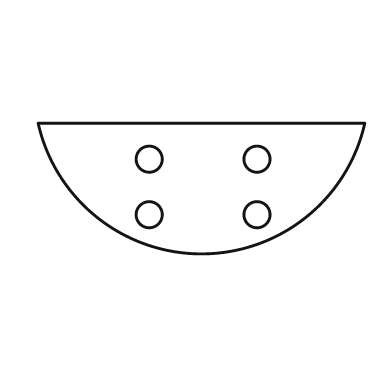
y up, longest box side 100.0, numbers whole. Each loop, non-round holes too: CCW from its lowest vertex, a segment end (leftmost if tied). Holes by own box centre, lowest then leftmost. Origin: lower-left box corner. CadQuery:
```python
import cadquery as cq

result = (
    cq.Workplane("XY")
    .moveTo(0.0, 40.0)
    .threePointArc((50.0, 0.0), (100.0, 40.0))
    .close()
    .moveTo(34.0, 12.0)
    .circle(4.0)
    .moveTo(67.0, 12.0)
    .circle(4.0)
    .moveTo(34.0, 29.0)
    .circle(4.0)
    .moveTo(67.0, 29.0)
    .circle(4.0)
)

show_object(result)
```